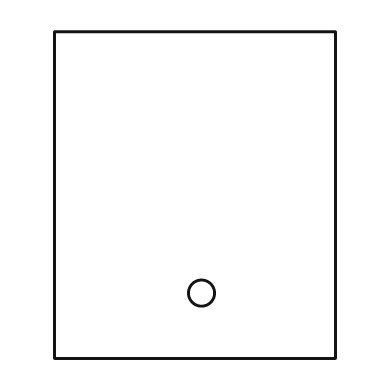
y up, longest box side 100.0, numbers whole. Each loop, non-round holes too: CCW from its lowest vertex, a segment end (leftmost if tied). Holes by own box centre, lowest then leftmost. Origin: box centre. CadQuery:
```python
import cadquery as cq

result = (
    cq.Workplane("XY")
    .moveTo(-43.0, -50.0)
    .lineTo(43.0, -50.0)
    .lineTo(43.0, 50.0)
    .lineTo(-43.0, 50.0)
    .close()
    .moveTo(2.0, -30.0)
    .circle(4.0)
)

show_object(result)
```